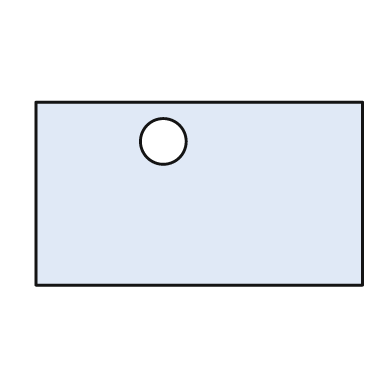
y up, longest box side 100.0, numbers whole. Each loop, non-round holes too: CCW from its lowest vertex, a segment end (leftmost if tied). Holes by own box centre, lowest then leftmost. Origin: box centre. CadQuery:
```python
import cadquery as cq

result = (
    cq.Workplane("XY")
    .moveTo(-50.0, -28.0)
    .lineTo(50.0, -28.0)
    .lineTo(50.0, 28.0)
    .lineTo(-50.0, 28.0)
    .close()
    .moveTo(-11.0, 16.0)
    .circle(7.0)
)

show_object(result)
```